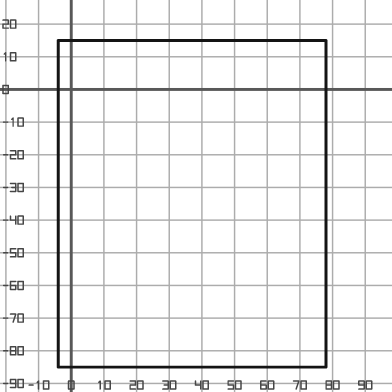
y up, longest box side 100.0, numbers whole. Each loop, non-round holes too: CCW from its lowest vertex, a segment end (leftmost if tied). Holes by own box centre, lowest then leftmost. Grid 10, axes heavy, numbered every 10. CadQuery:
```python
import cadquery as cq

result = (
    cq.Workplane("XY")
    .moveTo(-4.0, -85.0)
    .lineTo(78.0, -85.0)
    .lineTo(78.0, 15.0)
    .lineTo(-4.0, 15.0)
    .close()
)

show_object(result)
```